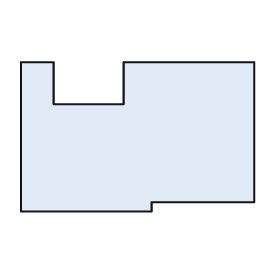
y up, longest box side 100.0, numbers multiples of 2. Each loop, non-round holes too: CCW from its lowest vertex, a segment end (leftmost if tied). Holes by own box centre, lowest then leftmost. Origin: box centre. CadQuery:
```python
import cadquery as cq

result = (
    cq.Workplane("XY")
    .moveTo(-50.0, -32.0)
    .lineTo(6.0, -32.0)
    .lineTo(6.0, -28.0)
    .lineTo(50.0, -28.0)
    .lineTo(50.0, 32.0)
    .lineTo(-6.0, 32.0)
    .lineTo(-6.0, 14.0)
    .lineTo(-36.0, 14.0)
    .lineTo(-36.0, 32.0)
    .lineTo(-50.0, 32.0)
    .close()
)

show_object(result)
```